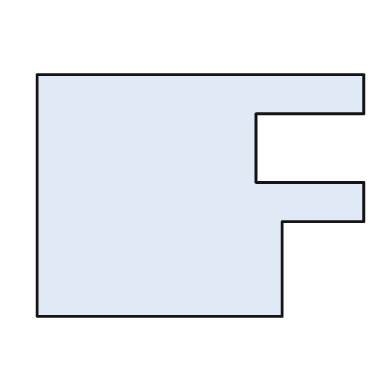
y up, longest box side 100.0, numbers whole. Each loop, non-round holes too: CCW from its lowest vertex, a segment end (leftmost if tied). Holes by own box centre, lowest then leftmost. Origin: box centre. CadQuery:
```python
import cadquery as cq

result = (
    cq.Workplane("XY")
    .moveTo(-50.0, -37.0)
    .lineTo(25.0, -37.0)
    .lineTo(25.0, -8.0)
    .lineTo(50.0, -8.0)
    .lineTo(50.0, 4.0)
    .lineTo(17.0, 4.0)
    .lineTo(17.0, 25.0)
    .lineTo(50.0, 25.0)
    .lineTo(50.0, 37.0)
    .lineTo(-50.0, 37.0)
    .close()
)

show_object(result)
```